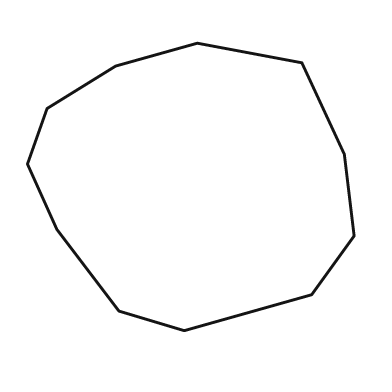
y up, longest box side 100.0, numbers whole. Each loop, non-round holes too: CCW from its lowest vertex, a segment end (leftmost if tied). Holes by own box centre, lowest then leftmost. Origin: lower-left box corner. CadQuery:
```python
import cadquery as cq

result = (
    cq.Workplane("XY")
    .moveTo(48.0, 0.0)
    .lineTo(87.0, 11.0)
    .lineTo(100.0, 29.0)
    .lineTo(97.0, 54.0)
    .lineTo(84.0, 82.0)
    .lineTo(52.0, 88.0)
    .lineTo(27.0, 81.0)
    .lineTo(6.0, 68.0)
    .lineTo(0.0, 51.0)
    .lineTo(9.0, 31.0)
    .lineTo(28.0, 6.0)
    .close()
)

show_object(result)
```